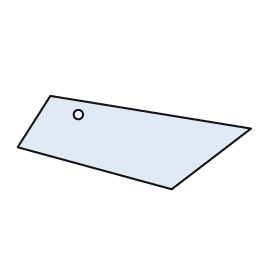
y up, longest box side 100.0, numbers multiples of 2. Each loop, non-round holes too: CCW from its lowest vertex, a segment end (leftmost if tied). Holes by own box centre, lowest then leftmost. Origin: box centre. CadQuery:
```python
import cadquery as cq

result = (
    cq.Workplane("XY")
    .moveTo(16.0, -20.0)
    .lineTo(50.0, 6.0)
    .lineTo(-36.0, 20.0)
    .lineTo(-50.0, -2.0)
    .close()
    .moveTo(-24.0, 12.0)
    .circle(2.0)
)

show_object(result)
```